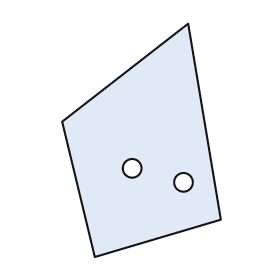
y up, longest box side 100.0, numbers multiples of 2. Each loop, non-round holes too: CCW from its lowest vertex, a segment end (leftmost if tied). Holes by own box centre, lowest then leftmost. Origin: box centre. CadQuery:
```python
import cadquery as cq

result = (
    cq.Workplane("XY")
    .moveTo(-20.0, -50.0)
    .lineTo(34.0, -34.0)
    .lineTo(20.0, 50.0)
    .lineTo(-34.0, 8.0)
    .close()
    .moveTo(18.0, -18.0)
    .circle(4.0)
    .moveTo(-4.0, -12.0)
    .circle(4.0)
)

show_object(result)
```